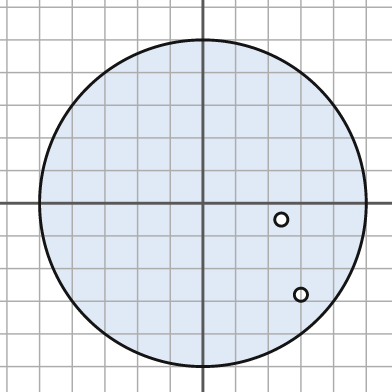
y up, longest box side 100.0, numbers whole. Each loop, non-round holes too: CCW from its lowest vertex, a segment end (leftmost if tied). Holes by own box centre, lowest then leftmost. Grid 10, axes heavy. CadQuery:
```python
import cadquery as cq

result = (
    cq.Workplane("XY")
    .moveTo(0.0, 0.0)
    .circle(50.0)
    .moveTo(30.0, -28.0)
    .circle(2.0)
    .moveTo(24.0, -5.0)
    .circle(2.0)
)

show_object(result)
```